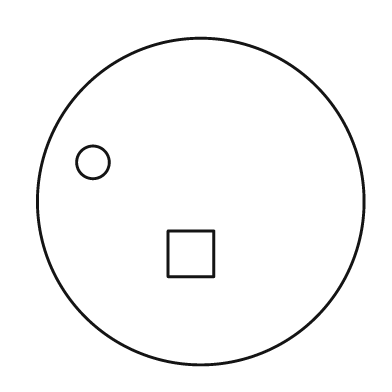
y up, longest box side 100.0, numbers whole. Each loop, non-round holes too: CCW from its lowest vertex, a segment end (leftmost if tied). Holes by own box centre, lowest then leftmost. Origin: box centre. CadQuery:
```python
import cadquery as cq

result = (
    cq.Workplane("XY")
    .moveTo(0.0, 0.0)
    .circle(50.0)
    .moveTo(-10.0, -23.0)
    .lineTo(4.0, -23.0)
    .lineTo(4.0, -9.0)
    .lineTo(-10.0, -9.0)
    .close()
    .moveTo(-33.0, 12.0)
    .circle(5.0)
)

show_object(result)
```